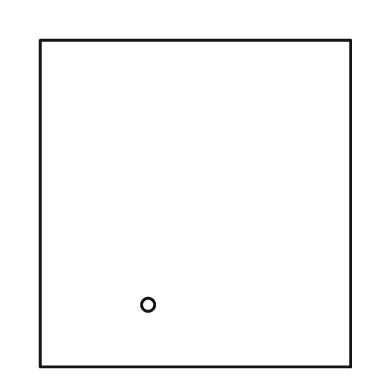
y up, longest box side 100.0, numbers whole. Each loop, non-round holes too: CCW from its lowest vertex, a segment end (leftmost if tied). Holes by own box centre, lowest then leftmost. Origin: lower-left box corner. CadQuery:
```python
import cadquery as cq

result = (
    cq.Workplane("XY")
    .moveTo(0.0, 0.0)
    .lineTo(95.0, 0.0)
    .lineTo(95.0, 100.0)
    .lineTo(0.0, 100.0)
    .close()
    .moveTo(33.0, 19.0)
    .circle(2.0)
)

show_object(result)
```